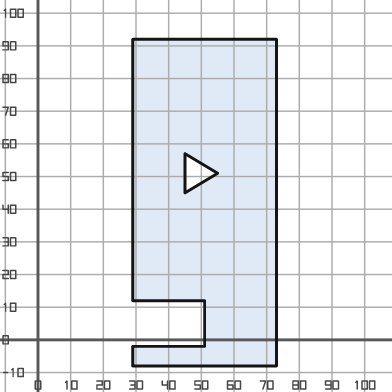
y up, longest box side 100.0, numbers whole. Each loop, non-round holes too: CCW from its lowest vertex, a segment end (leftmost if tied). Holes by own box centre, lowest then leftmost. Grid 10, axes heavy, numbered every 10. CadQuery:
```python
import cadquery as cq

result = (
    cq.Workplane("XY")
    .moveTo(29.0, -8.0)
    .lineTo(73.0, -8.0)
    .lineTo(73.0, 92.0)
    .lineTo(29.0, 92.0)
    .lineTo(29.0, 12.0)
    .lineTo(51.0, 12.0)
    .lineTo(51.0, -2.0)
    .lineTo(29.0, -2.0)
    .close()
    .moveTo(45.0, 45.0)
    .lineTo(55.0, 51.0)
    .lineTo(45.0, 57.0)
    .close()
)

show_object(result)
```